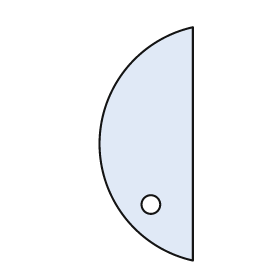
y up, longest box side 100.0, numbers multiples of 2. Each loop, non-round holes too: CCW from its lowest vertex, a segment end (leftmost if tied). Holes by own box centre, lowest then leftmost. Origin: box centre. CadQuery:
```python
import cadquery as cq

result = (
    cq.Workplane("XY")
    .moveTo(20.0, -50.0)
    .lineTo(20.0, 50.0)
    .threePointArc((-20.0, 0.0), (20.0, -50.0))
    .close()
    .moveTo(2.0, -26.0)
    .circle(4.0)
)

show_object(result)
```